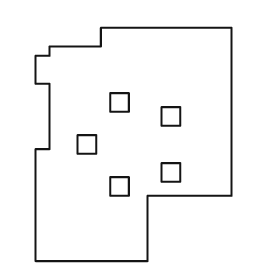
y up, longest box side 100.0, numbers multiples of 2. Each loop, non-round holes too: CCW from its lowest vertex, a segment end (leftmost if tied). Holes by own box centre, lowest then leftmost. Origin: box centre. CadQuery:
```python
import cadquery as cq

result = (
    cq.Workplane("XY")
    .moveTo(-42.0, -50.0)
    .lineTo(6.0, -50.0)
    .lineTo(6.0, -22.0)
    .lineTo(42.0, -22.0)
    .lineTo(42.0, 50.0)
    .lineTo(-14.0, 50.0)
    .lineTo(-14.0, 42.0)
    .lineTo(-36.0, 42.0)
    .lineTo(-36.0, 38.0)
    .lineTo(-42.0, 38.0)
    .lineTo(-42.0, 26.0)
    .lineTo(-36.0, 26.0)
    .lineTo(-36.0, -2.0)
    .lineTo(-42.0, -2.0)
    .close()
    .moveTo(-10.0, -22.0)
    .lineTo(-2.0, -22.0)
    .lineTo(-2.0, -14.0)
    .lineTo(-10.0, -14.0)
    .close()
    .moveTo(12.0, -16.0)
    .lineTo(20.0, -16.0)
    .lineTo(20.0, -8.0)
    .lineTo(12.0, -8.0)
    .close()
    .moveTo(-24.0, -4.0)
    .lineTo(-16.0, -4.0)
    .lineTo(-16.0, 4.0)
    .lineTo(-24.0, 4.0)
    .close()
    .moveTo(12.0, 8.0)
    .lineTo(20.0, 8.0)
    .lineTo(20.0, 16.0)
    .lineTo(12.0, 16.0)
    .close()
    .moveTo(-10.0, 14.0)
    .lineTo(-2.0, 14.0)
    .lineTo(-2.0, 22.0)
    .lineTo(-10.0, 22.0)
    .close()
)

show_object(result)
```